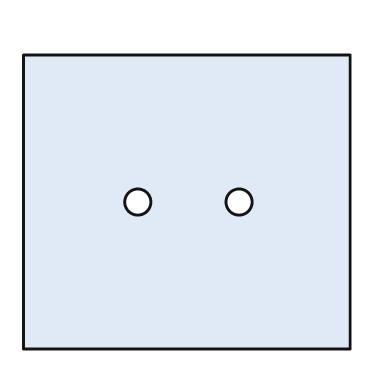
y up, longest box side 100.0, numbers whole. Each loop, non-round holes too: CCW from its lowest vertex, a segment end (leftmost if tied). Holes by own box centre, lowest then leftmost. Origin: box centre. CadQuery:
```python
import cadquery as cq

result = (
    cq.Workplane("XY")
    .moveTo(-50.0, -45.0)
    .lineTo(50.0, -45.0)
    .lineTo(50.0, 45.0)
    .lineTo(-50.0, 45.0)
    .close()
    .moveTo(-15.0, 0.0)
    .circle(4.0)
    .moveTo(16.0, 0.0)
    .circle(4.0)
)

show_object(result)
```